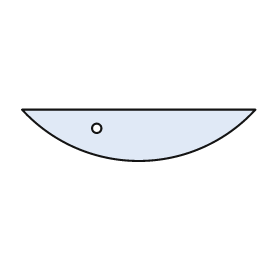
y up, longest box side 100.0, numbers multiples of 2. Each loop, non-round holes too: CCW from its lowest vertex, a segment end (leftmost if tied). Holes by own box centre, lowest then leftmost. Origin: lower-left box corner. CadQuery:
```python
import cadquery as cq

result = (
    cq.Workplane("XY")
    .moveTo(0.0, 22.0)
    .threePointArc((50.0, 0.0), (100.0, 22.0))
    .close()
    .moveTo(32.0, 14.0)
    .circle(2.0)
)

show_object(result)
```